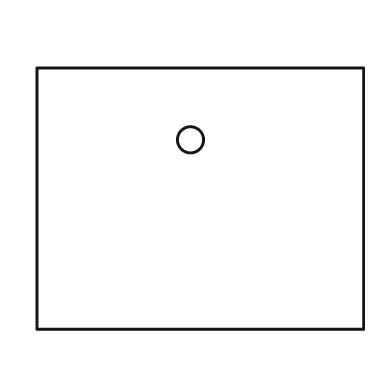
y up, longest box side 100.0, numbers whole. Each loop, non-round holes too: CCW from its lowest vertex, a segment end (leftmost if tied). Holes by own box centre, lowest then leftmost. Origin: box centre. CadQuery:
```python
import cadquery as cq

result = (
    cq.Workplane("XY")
    .moveTo(-50.0, -40.0)
    .lineTo(50.0, -40.0)
    .lineTo(50.0, 40.0)
    .lineTo(-50.0, 40.0)
    .close()
    .moveTo(-3.0, 18.0)
    .circle(4.0)
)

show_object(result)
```